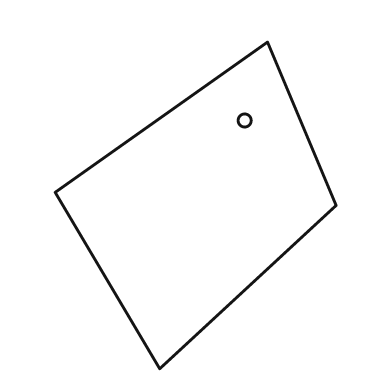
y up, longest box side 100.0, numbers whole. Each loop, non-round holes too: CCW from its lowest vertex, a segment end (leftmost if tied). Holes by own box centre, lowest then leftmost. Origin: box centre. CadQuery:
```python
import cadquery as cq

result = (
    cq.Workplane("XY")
    .moveTo(-11.0, -50.0)
    .lineTo(43.0, 0.0)
    .lineTo(22.0, 50.0)
    .lineTo(-43.0, 4.0)
    .close()
    .moveTo(15.0, 26.0)
    .circle(2.0)
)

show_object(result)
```